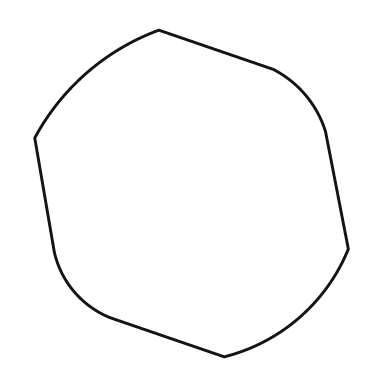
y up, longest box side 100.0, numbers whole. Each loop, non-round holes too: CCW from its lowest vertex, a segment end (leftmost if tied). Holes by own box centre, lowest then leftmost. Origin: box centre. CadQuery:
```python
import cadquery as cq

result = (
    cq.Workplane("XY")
    .moveTo(10.0, -50.0)
    .threePointArc((33.0, -38.0), (48.0, -17.0))
    .lineTo(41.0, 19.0)
    .threePointArc((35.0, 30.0), (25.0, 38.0))
    .lineTo(-10.0, 50.0)
    .threePointArc((-32.0, 37.0), (-48.0, 17.0))
    .lineTo(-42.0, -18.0)
    .threePointArc((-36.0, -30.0), (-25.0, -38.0))
    .close()
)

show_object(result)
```